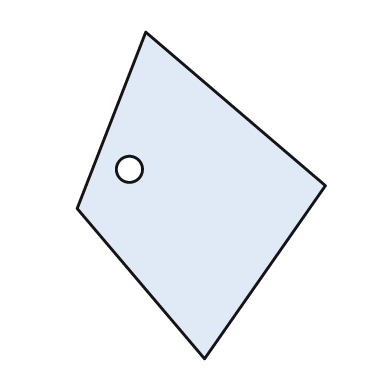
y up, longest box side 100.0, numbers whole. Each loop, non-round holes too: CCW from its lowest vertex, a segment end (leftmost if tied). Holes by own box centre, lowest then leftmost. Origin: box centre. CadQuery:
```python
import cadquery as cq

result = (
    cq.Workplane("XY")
    .moveTo(1.0, -50.0)
    .lineTo(38.0, 3.0)
    .lineTo(-17.0, 50.0)
    .lineTo(-38.0, -4.0)
    .close()
    .moveTo(-22.0, 8.0)
    .circle(4.0)
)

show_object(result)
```